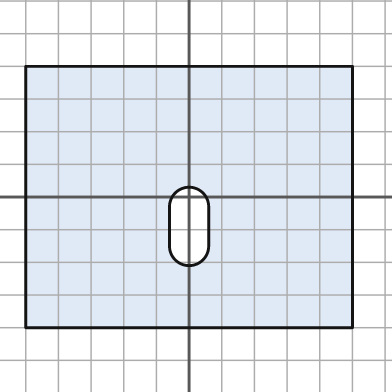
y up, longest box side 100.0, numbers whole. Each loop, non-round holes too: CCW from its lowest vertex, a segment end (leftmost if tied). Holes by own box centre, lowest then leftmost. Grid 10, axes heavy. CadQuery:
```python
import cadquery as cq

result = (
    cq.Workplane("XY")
    .moveTo(-50.0, -40.0)
    .lineTo(50.0, -40.0)
    .lineTo(50.0, 40.0)
    .lineTo(-50.0, 40.0)
    .close()
    .moveTo(-6.0, -15.0)
    .threePointArc((0.0, -21.0), (6.0, -15.0))
    .lineTo(6.0, -3.0)
    .threePointArc((0.0, 3.0), (-6.0, -3.0))
    .close()
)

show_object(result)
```